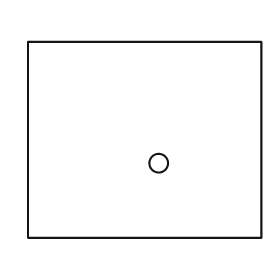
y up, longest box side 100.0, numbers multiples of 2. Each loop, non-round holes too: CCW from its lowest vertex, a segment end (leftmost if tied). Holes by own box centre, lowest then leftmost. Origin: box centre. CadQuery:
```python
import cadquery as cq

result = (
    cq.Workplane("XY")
    .moveTo(-50.0, -42.0)
    .lineTo(50.0, -42.0)
    .lineTo(50.0, 42.0)
    .lineTo(-50.0, 42.0)
    .close()
    .moveTo(6.0, -10.0)
    .circle(4.0)
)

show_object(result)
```